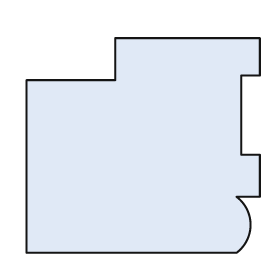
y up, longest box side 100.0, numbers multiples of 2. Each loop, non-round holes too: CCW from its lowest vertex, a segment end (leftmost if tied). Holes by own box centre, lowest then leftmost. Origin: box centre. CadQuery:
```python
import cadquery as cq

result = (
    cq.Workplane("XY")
    .moveTo(-50.0, -46.0)
    .lineTo(40.0, -46.0)
    .threePointArc((46.0, -34.0), (40.0, -22.0))
    .lineTo(50.0, -22.0)
    .lineTo(50.0, -4.0)
    .lineTo(42.0, -4.0)
    .lineTo(42.0, 30.0)
    .lineTo(50.0, 30.0)
    .lineTo(50.0, 46.0)
    .lineTo(-12.0, 46.0)
    .lineTo(-12.0, 28.0)
    .lineTo(-50.0, 28.0)
    .close()
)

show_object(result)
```